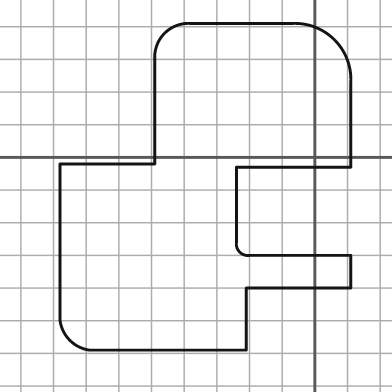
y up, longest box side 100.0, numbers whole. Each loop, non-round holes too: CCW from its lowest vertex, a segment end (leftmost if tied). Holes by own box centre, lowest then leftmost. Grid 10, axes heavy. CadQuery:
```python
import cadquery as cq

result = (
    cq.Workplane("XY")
    .moveTo(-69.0, -59.0)
    .lineTo(-21.0, -59.0)
    .lineTo(-21.0, -40.0)
    .lineTo(11.0, -40.0)
    .lineTo(11.0, -30.0)
    .lineTo(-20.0, -30.0)
    .threePointArc((-23.0, -29.0), (-24.0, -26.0))
    .lineTo(-24.0, -3.0)
    .lineTo(11.0, -3.0)
    .lineTo(11.0, 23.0)
    .threePointArc((6.0, 36.0), (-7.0, 41.0))
    .lineTo(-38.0, 41.0)
    .threePointArc((-46.0, 38.0), (-49.0, 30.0))
    .lineTo(-49.0, -2.0)
    .lineTo(-78.0, -2.0)
    .lineTo(-78.0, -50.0)
    .threePointArc((-75.0, -56.0), (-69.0, -59.0))
    .close()
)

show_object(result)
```